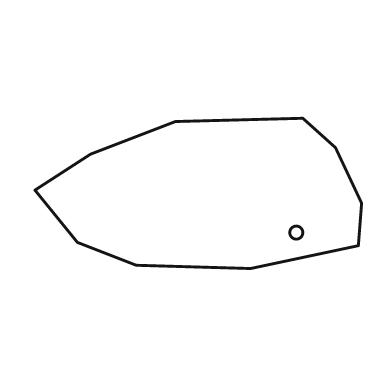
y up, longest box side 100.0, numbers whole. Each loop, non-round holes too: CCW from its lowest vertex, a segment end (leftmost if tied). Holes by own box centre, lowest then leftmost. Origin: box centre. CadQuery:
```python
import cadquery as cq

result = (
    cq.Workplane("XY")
    .moveTo(16.0, -23.0)
    .lineTo(49.0, -16.0)
    .lineTo(50.0, -3.0)
    .lineTo(42.0, 14.0)
    .lineTo(32.0, 23.0)
    .lineTo(-7.0, 22.0)
    .lineTo(-33.0, 12.0)
    .lineTo(-50.0, 1.0)
    .lineTo(-37.0, -15.0)
    .lineTo(-19.0, -22.0)
    .close()
    .moveTo(30.0, -12.0)
    .circle(2.0)
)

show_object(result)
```